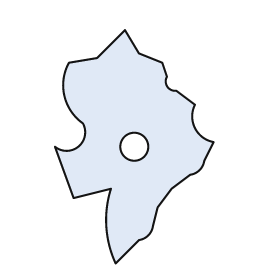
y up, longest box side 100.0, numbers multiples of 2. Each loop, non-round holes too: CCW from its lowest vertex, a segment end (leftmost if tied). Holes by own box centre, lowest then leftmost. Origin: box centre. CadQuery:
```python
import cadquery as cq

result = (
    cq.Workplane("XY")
    .moveTo(-8.0, -50.0)
    .lineTo(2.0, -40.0)
    .threePointArc((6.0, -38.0), (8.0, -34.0))
    .lineTo(10.0, -26.0)
    .lineTo(16.0, -18.0)
    .lineTo(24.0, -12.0)
    .threePointArc((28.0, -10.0), (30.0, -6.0))
    .lineTo(34.0, 2.0)
    .threePointArc((26.0, 8.0), (26.0, 18.0))
    .lineTo(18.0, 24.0)
    .threePointArc((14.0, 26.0), (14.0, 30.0))
    .lineTo(12.0, 36.0)
    .lineTo(2.0, 40.0)
    .lineTo(-4.0, 50.0)
    .lineTo(-16.0, 38.0)
    .lineTo(-28.0, 36.0)
    .threePointArc((-30.0, 22.0), (-22.0, 10.0))
    .threePointArc((-24.0, 0.0), (-34.0, 0.0))
    .lineTo(-26.0, -22.0)
    .lineTo(-10.0, -18.0)
    .threePointArc((-12.0, -34.0), (-8.0, -50.0))
    .close()
    .moveTo(0.0, 0.0)
    .circle(6.0)
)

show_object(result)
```